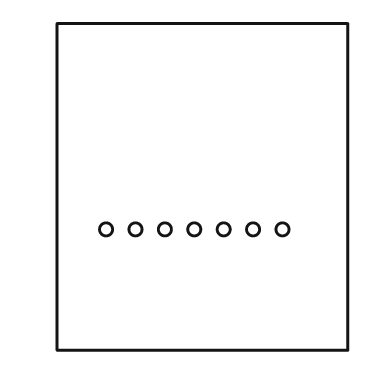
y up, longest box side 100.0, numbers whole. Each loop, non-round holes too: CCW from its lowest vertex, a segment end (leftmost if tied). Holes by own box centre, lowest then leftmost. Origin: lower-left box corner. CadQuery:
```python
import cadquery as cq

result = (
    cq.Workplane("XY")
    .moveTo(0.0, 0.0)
    .lineTo(89.0, 0.0)
    .lineTo(89.0, 100.0)
    .lineTo(0.0, 100.0)
    .close()
    .moveTo(15.0, 37.0)
    .circle(2.0)
    .moveTo(24.0, 37.0)
    .circle(2.0)
    .moveTo(33.0, 37.0)
    .circle(2.0)
    .moveTo(42.0, 37.0)
    .circle(2.0)
    .moveTo(51.0, 37.0)
    .circle(2.0)
    .moveTo(60.0, 37.0)
    .circle(2.0)
    .moveTo(69.0, 37.0)
    .circle(2.0)
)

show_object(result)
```